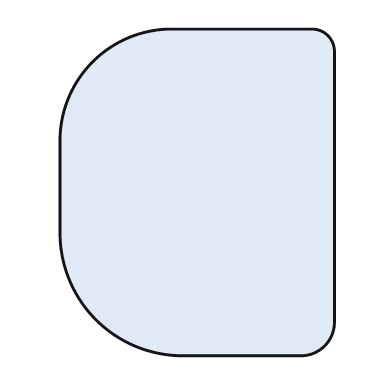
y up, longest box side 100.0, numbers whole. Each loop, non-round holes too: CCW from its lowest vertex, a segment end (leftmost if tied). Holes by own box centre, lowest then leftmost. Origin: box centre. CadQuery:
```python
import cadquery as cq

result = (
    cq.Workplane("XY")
    .moveTo(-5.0, -50.0)
    .lineTo(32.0, -50.0)
    .threePointArc((39.0, -47.0), (42.0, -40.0))
    .lineTo(42.0, 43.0)
    .threePointArc((40.0, 48.0), (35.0, 50.0))
    .lineTo(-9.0, 50.0)
    .threePointArc((-32.0, 40.0), (-42.0, 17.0))
    .lineTo(-42.0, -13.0)
    .threePointArc((-31.0, -39.0), (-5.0, -50.0))
    .close()
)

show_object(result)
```